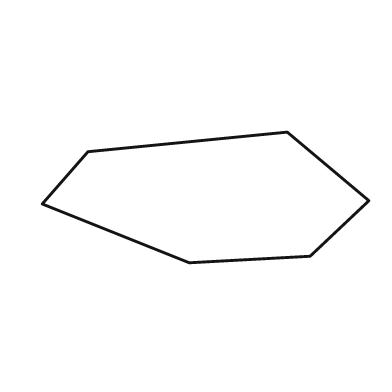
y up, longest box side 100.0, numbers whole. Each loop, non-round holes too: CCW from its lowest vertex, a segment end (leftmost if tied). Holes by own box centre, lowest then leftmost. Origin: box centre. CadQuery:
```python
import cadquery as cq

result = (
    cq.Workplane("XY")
    .moveTo(-5.0, -20.0)
    .lineTo(32.0, -18.0)
    .lineTo(50.0, -1.0)
    .lineTo(25.0, 20.0)
    .lineTo(-36.0, 14.0)
    .lineTo(-50.0, -2.0)
    .close()
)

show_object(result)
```